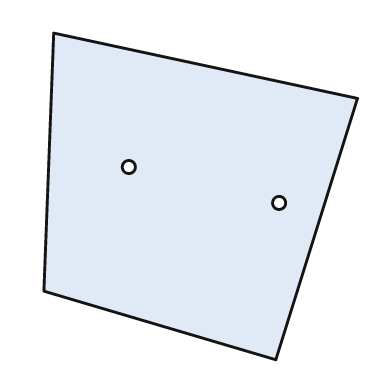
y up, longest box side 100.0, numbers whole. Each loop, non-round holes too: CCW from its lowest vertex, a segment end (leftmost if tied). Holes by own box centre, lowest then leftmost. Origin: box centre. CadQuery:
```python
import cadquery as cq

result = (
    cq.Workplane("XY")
    .moveTo(23.0, -50.0)
    .lineTo(48.0, 30.0)
    .lineTo(-45.0, 50.0)
    .lineTo(-48.0, -29.0)
    .close()
    .moveTo(24.0, -2.0)
    .circle(2.0)
    .moveTo(-22.0, 9.0)
    .circle(2.0)
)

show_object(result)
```